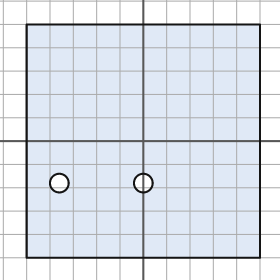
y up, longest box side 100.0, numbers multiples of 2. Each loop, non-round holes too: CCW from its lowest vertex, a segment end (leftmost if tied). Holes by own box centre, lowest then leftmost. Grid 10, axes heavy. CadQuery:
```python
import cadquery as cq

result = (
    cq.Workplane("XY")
    .moveTo(-50.0, -50.0)
    .lineTo(50.0, -50.0)
    .lineTo(50.0, 50.0)
    .lineTo(-50.0, 50.0)
    .close()
    .moveTo(-36.0, -18.0)
    .circle(4.0)
    .moveTo(0.0, -18.0)
    .circle(4.0)
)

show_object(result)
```